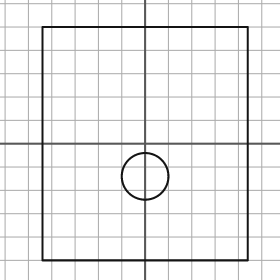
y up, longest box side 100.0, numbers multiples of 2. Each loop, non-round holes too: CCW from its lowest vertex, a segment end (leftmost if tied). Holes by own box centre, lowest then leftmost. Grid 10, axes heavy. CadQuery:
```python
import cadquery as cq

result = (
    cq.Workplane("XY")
    .moveTo(-44.0, -50.0)
    .lineTo(44.0, -50.0)
    .lineTo(44.0, 50.0)
    .lineTo(-44.0, 50.0)
    .close()
    .moveTo(0.0, -14.0)
    .circle(10.0)
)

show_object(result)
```